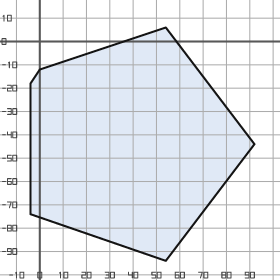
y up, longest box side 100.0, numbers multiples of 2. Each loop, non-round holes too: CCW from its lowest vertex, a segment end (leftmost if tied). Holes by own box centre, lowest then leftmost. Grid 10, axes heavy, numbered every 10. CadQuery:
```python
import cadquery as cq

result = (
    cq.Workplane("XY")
    .moveTo(54.0, -94.0)
    .lineTo(92.0, -44.0)
    .lineTo(54.0, 6.0)
    .lineTo(0.0, -12.0)
    .lineTo(-4.0, -18.0)
    .lineTo(-4.0, -74.0)
    .close()
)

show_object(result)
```